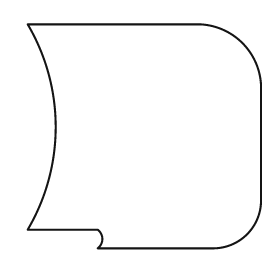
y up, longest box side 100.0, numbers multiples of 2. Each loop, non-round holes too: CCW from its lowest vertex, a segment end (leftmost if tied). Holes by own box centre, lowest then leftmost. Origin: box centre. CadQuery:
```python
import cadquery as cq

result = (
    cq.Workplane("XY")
    .moveTo(-20.0, -48.0)
    .lineTo(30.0, -48.0)
    .threePointArc((44.0, -42.0), (50.0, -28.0))
    .lineTo(50.0, 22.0)
    .threePointArc((42.0, 40.0), (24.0, 48.0))
    .lineTo(-50.0, 48.0)
    .threePointArc((-38.0, 4.0), (-50.0, -40.0))
    .lineTo(-20.0, -40.0)
    .threePointArc((-18.0, -44.0), (-20.0, -48.0))
    .close()
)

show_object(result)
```